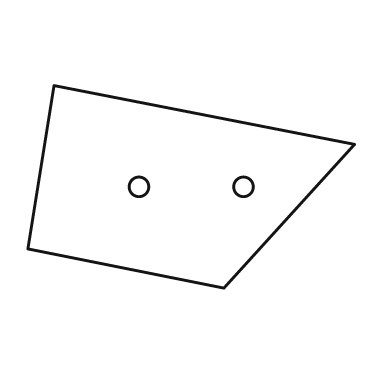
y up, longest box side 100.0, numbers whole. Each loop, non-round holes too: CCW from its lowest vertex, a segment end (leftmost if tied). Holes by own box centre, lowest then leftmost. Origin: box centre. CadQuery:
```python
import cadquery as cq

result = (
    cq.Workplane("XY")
    .moveTo(10.0, -31.0)
    .lineTo(50.0, 13.0)
    .lineTo(-42.0, 31.0)
    .lineTo(-50.0, -19.0)
    .close()
    .moveTo(-16.0, 0.0)
    .circle(3.0)
    .moveTo(16.0, 0.0)
    .circle(3.0)
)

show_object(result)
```